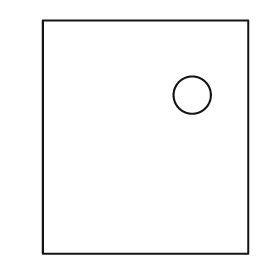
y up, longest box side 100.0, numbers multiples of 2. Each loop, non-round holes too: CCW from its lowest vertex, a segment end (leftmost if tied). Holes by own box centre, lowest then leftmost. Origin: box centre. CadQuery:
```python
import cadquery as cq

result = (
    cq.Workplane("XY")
    .moveTo(-44.0, -50.0)
    .lineTo(44.0, -50.0)
    .lineTo(44.0, 50.0)
    .lineTo(-44.0, 50.0)
    .close()
    .moveTo(20.0, 18.0)
    .circle(8.0)
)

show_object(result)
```